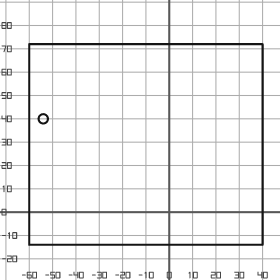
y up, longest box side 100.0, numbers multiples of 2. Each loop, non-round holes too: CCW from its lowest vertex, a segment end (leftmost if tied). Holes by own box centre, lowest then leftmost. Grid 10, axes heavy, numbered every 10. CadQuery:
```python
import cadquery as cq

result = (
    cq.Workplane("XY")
    .moveTo(-60.0, -14.0)
    .lineTo(40.0, -14.0)
    .lineTo(40.0, 72.0)
    .lineTo(-60.0, 72.0)
    .close()
    .moveTo(-54.0, 40.0)
    .circle(2.0)
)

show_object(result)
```